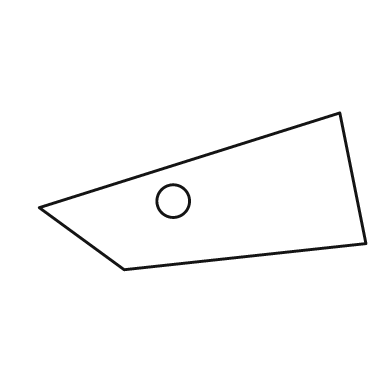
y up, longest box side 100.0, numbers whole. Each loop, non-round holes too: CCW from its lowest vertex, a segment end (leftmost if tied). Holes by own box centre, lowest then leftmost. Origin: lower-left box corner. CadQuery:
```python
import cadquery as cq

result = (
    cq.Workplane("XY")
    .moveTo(26.0, 0.0)
    .lineTo(100.0, 8.0)
    .lineTo(92.0, 48.0)
    .lineTo(0.0, 19.0)
    .close()
    .moveTo(41.0, 21.0)
    .circle(5.0)
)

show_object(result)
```